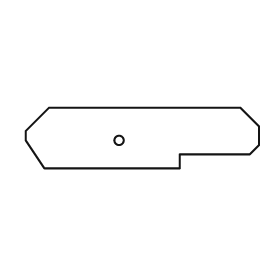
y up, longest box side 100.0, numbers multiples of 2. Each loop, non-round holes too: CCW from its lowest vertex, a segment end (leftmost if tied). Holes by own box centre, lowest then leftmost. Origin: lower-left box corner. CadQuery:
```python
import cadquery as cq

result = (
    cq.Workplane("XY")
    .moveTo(8.0, 0.0)
    .lineTo(66.0, 0.0)
    .lineTo(66.0, 6.0)
    .lineTo(96.0, 6.0)
    .lineTo(100.0, 10.0)
    .lineTo(100.0, 18.0)
    .lineTo(92.0, 26.0)
    .lineTo(10.0, 26.0)
    .lineTo(0.0, 16.0)
    .lineTo(0.0, 12.0)
    .close()
    .moveTo(40.0, 12.0)
    .circle(2.0)
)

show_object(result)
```